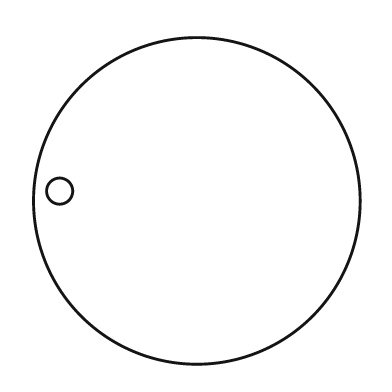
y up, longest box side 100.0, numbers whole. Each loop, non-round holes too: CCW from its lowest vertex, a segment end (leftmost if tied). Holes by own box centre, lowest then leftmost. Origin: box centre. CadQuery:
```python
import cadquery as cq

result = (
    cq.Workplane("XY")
    .moveTo(0.0, 0.0)
    .circle(50.0)
    .moveTo(-42.0, 3.0)
    .circle(4.0)
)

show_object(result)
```